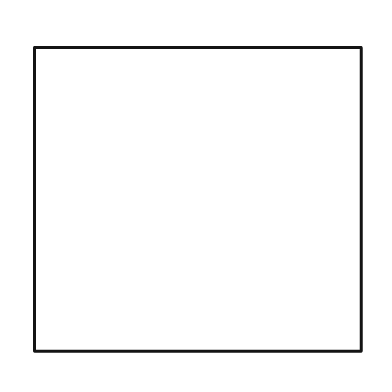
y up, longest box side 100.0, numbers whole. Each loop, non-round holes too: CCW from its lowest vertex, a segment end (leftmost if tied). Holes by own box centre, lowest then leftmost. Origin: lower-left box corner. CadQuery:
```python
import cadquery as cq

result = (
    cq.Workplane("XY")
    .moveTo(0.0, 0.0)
    .lineTo(100.0, 0.0)
    .lineTo(100.0, 93.0)
    .lineTo(0.0, 93.0)
    .close()
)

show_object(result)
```